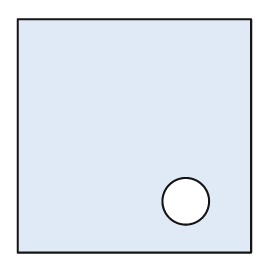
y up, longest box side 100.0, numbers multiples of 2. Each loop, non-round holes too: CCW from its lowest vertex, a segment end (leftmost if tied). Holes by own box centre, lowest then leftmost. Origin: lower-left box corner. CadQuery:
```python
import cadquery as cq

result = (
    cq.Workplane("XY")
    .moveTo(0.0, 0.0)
    .lineTo(100.0, 0.0)
    .lineTo(100.0, 100.0)
    .lineTo(0.0, 100.0)
    .close()
    .moveTo(72.0, 22.0)
    .circle(10.0)
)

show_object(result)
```